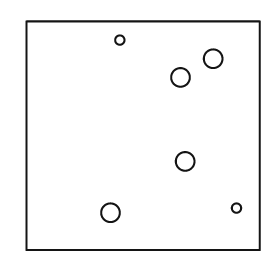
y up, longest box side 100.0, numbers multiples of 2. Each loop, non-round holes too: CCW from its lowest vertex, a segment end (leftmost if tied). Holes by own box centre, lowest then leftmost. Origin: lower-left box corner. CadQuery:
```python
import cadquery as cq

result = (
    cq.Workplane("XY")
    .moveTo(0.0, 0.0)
    .lineTo(100.0, 0.0)
    .lineTo(100.0, 98.0)
    .lineTo(0.0, 98.0)
    .close()
    .moveTo(36.0, 16.0)
    .circle(4.0)
    .moveTo(90.0, 18.0)
    .circle(2.0)
    .moveTo(68.0, 38.0)
    .circle(4.0)
    .moveTo(66.0, 74.0)
    .circle(4.0)
    .moveTo(80.0, 82.0)
    .circle(4.0)
    .moveTo(40.0, 90.0)
    .circle(2.0)
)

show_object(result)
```